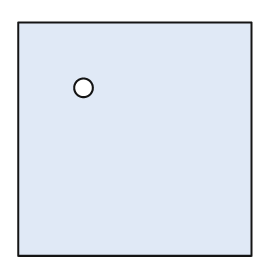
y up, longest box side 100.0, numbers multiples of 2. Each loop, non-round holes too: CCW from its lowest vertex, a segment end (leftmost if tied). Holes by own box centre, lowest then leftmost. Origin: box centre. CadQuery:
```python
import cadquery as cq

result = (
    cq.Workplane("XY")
    .moveTo(-50.0, -50.0)
    .lineTo(50.0, -50.0)
    .lineTo(50.0, 50.0)
    .lineTo(-50.0, 50.0)
    .close()
    .moveTo(-22.0, 22.0)
    .circle(4.0)
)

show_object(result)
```